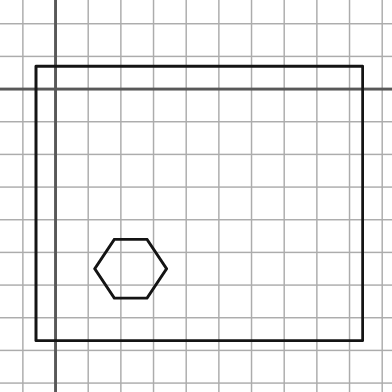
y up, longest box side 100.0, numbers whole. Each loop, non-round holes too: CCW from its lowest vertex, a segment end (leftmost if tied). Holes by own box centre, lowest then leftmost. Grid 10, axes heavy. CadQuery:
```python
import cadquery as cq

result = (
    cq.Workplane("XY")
    .moveTo(-6.0, -77.0)
    .lineTo(94.0, -77.0)
    .lineTo(94.0, 7.0)
    .lineTo(-6.0, 7.0)
    .close()
    .moveTo(18.0, -64.0)
    .lineTo(28.0, -64.0)
    .lineTo(34.0, -55.0)
    .lineTo(28.0, -46.0)
    .lineTo(18.0, -46.0)
    .lineTo(12.0, -55.0)
    .close()
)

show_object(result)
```